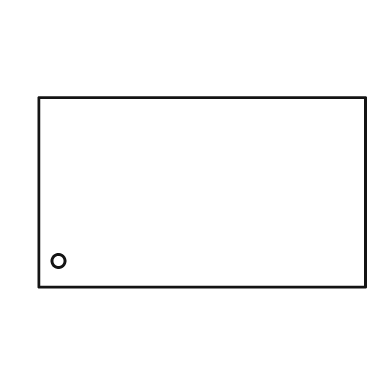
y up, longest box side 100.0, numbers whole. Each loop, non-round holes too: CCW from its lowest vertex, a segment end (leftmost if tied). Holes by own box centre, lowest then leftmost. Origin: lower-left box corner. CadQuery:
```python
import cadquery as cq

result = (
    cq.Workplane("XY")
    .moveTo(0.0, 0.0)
    .lineTo(100.0, 0.0)
    .lineTo(100.0, 58.0)
    .lineTo(0.0, 58.0)
    .close()
    .moveTo(6.0, 8.0)
    .circle(2.0)
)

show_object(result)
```